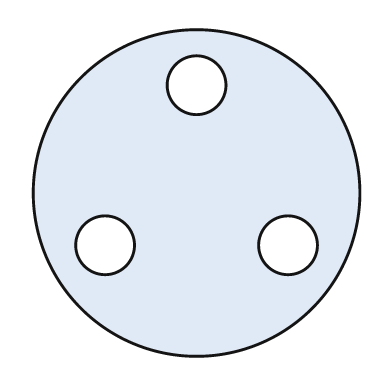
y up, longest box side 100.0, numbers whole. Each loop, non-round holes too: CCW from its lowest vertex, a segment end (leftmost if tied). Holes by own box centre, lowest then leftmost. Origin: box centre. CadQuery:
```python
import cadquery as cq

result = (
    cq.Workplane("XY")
    .moveTo(0.0, 0.0)
    .circle(50.0)
    .moveTo(-28.0, -16.0)
    .circle(9.0)
    .moveTo(28.0, -16.0)
    .circle(9.0)
    .moveTo(0.0, 33.0)
    .circle(9.0)
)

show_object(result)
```